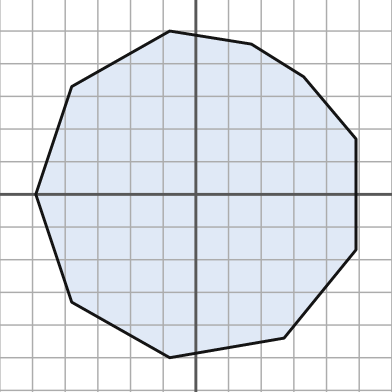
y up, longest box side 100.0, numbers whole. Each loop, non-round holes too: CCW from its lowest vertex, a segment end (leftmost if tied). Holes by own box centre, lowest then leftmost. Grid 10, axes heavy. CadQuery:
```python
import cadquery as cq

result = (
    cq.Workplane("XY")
    .moveTo(-8.0, -50.0)
    .lineTo(27.0, -44.0)
    .lineTo(49.0, -17.0)
    .lineTo(49.0, 17.0)
    .lineTo(33.0, 36.0)
    .lineTo(17.0, 46.0)
    .lineTo(-8.0, 50.0)
    .lineTo(-38.0, 33.0)
    .lineTo(-49.0, 0.0)
    .lineTo(-38.0, -33.0)
    .close()
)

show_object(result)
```